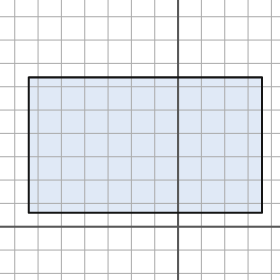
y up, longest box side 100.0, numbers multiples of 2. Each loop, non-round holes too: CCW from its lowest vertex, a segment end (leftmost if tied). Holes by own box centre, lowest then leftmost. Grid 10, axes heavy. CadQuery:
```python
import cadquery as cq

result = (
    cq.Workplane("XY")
    .moveTo(-64.0, 6.0)
    .lineTo(36.0, 6.0)
    .lineTo(36.0, 64.0)
    .lineTo(-64.0, 64.0)
    .close()
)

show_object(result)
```